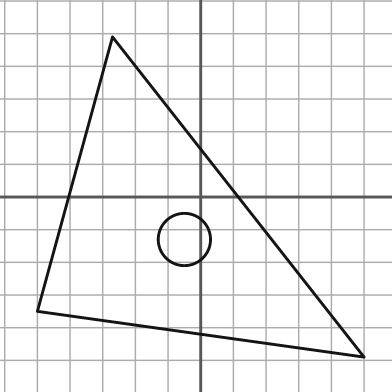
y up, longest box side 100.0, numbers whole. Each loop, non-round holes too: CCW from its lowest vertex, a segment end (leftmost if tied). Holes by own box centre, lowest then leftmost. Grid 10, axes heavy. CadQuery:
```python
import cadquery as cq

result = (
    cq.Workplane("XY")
    .moveTo(50.0, -49.0)
    .lineTo(-27.0, 49.0)
    .lineTo(-50.0, -35.0)
    .close()
    .moveTo(-5.0, -13.0)
    .circle(8.0)
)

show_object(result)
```